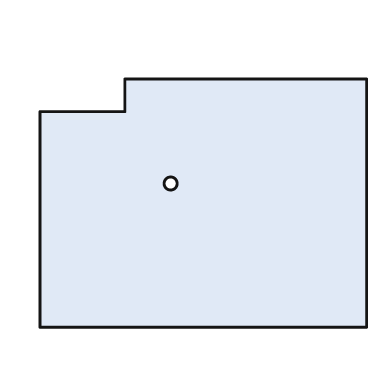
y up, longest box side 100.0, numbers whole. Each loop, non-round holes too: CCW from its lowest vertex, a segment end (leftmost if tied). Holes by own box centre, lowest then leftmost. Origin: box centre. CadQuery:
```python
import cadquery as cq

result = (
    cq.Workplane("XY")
    .moveTo(-50.0, -38.0)
    .lineTo(50.0, -38.0)
    .lineTo(50.0, 38.0)
    .lineTo(-24.0, 38.0)
    .lineTo(-24.0, 28.0)
    .lineTo(-50.0, 28.0)
    .close()
    .moveTo(-10.0, 6.0)
    .circle(2.0)
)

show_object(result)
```